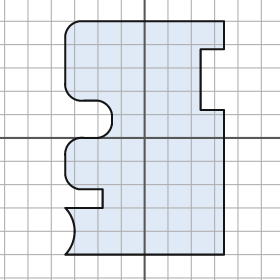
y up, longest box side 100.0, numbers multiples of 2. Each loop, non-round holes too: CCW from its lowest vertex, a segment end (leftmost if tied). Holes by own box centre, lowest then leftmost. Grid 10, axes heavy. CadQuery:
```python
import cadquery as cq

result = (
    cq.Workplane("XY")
    .moveTo(-34.0, -50.0)
    .lineTo(34.0, -50.0)
    .lineTo(34.0, 12.0)
    .lineTo(24.0, 12.0)
    .lineTo(24.0, 38.0)
    .lineTo(34.0, 38.0)
    .lineTo(34.0, 50.0)
    .lineTo(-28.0, 50.0)
    .threePointArc((-32.0, 48.0), (-34.0, 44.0))
    .lineTo(-34.0, 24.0)
    .threePointArc((-32.0, 18.0), (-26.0, 16.0))
    .lineTo(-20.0, 16.0)
    .threePointArc((-16.0, 14.0), (-14.0, 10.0))
    .lineTo(-14.0, 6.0)
    .threePointArc((-16.0, 2.0), (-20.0, 0.0))
    .lineTo(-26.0, 0.0)
    .threePointArc((-32.0, -2.0), (-34.0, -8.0))
    .lineTo(-34.0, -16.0)
    .threePointArc((-32.0, -20.0), (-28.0, -22.0))
    .lineTo(-18.0, -22.0)
    .lineTo(-18.0, -30.0)
    .lineTo(-34.0, -30.0)
    .threePointArc((-30.0, -40.0), (-34.0, -50.0))
    .close()
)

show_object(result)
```